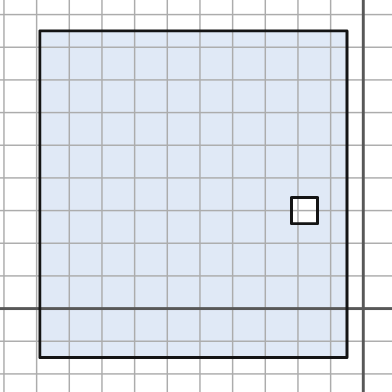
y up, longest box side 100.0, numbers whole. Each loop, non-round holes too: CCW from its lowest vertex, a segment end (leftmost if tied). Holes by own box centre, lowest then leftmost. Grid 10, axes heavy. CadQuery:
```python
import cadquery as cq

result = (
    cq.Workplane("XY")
    .moveTo(-99.0, -15.0)
    .lineTo(-5.0, -15.0)
    .lineTo(-5.0, 85.0)
    .lineTo(-99.0, 85.0)
    .close()
    .moveTo(-22.0, 26.0)
    .lineTo(-14.0, 26.0)
    .lineTo(-14.0, 34.0)
    .lineTo(-22.0, 34.0)
    .close()
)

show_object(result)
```